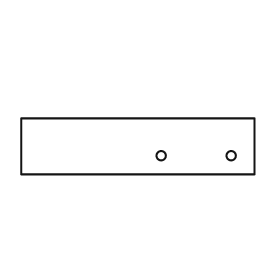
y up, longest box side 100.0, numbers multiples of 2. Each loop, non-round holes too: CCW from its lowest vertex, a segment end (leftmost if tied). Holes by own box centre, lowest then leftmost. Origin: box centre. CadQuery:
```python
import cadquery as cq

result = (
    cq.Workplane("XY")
    .moveTo(-50.0, -12.0)
    .lineTo(50.0, -12.0)
    .lineTo(50.0, 12.0)
    .lineTo(-50.0, 12.0)
    .close()
    .moveTo(10.0, -4.0)
    .circle(2.0)
    .moveTo(40.0, -4.0)
    .circle(2.0)
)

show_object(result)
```